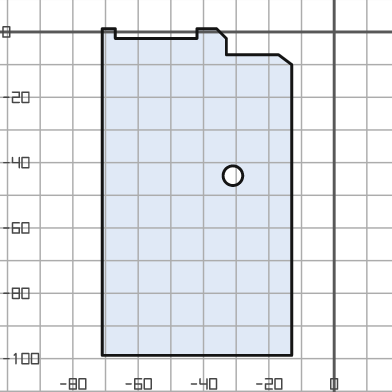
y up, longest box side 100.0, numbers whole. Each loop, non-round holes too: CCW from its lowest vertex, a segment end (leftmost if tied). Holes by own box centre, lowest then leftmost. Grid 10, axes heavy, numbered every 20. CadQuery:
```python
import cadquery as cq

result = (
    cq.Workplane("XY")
    .moveTo(-71.0, -99.0)
    .lineTo(-13.0, -99.0)
    .lineTo(-13.0, -10.0)
    .lineTo(-17.0, -7.0)
    .lineTo(-33.0, -7.0)
    .lineTo(-33.0, -2.0)
    .lineTo(-36.0, 1.0)
    .lineTo(-42.0, 1.0)
    .lineTo(-42.0, -2.0)
    .lineTo(-67.0, -2.0)
    .lineTo(-67.0, 1.0)
    .lineTo(-71.0, 1.0)
    .close()
    .moveTo(-31.0, -44.0)
    .circle(3.0)
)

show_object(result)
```